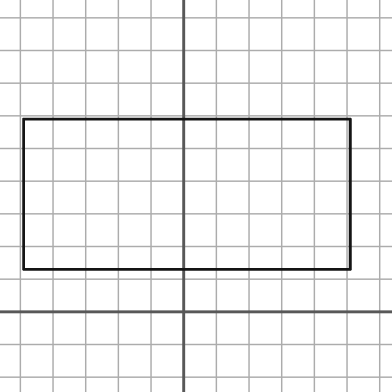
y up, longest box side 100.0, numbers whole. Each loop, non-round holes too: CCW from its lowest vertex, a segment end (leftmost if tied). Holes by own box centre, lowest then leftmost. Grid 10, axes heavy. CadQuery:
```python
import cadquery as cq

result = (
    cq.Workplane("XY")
    .moveTo(-49.0, 13.0)
    .lineTo(51.0, 13.0)
    .lineTo(51.0, 59.0)
    .lineTo(-49.0, 59.0)
    .close()
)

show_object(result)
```